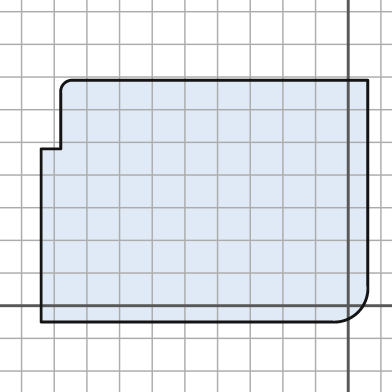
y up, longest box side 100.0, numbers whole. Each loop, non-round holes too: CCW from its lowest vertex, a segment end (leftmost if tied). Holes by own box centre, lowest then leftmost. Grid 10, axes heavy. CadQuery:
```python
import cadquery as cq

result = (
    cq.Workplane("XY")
    .moveTo(-94.0, -5.0)
    .lineTo(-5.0, -5.0)
    .threePointArc((3.0, -2.0), (6.0, 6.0))
    .lineTo(6.0, 69.0)
    .lineTo(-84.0, 69.0)
    .threePointArc((-87.0, 68.0), (-88.0, 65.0))
    .lineTo(-88.0, 48.0)
    .lineTo(-94.0, 48.0)
    .close()
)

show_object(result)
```